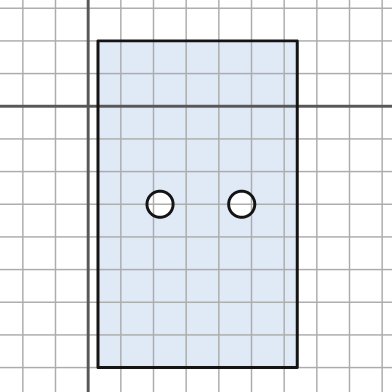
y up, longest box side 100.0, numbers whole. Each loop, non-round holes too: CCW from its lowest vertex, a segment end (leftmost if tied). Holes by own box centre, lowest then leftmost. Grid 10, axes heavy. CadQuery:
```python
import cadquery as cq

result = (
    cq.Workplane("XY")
    .moveTo(3.0, -80.0)
    .lineTo(64.0, -80.0)
    .lineTo(64.0, 20.0)
    .lineTo(3.0, 20.0)
    .close()
    .moveTo(22.0, -30.0)
    .circle(4.0)
    .moveTo(47.0, -30.0)
    .circle(4.0)
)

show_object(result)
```